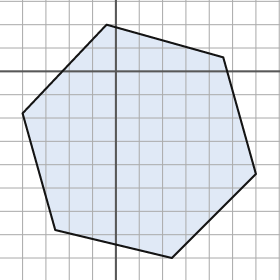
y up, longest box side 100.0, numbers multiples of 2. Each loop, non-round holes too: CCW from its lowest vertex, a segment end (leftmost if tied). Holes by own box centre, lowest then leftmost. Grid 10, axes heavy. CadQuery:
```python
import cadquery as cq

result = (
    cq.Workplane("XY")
    .moveTo(24.0, -80.0)
    .lineTo(60.0, -44.0)
    .lineTo(46.0, 6.0)
    .lineTo(-4.0, 20.0)
    .lineTo(-40.0, -18.0)
    .lineTo(-26.0, -68.0)
    .close()
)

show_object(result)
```